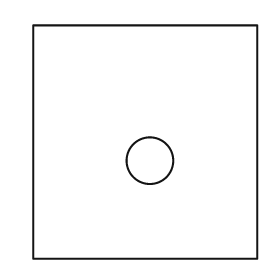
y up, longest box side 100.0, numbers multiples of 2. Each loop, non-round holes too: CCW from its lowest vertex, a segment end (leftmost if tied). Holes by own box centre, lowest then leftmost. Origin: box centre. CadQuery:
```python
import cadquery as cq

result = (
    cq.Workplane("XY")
    .moveTo(-48.0, -50.0)
    .lineTo(48.0, -50.0)
    .lineTo(48.0, 50.0)
    .lineTo(-48.0, 50.0)
    .close()
    .moveTo(2.0, -8.0)
    .circle(10.0)
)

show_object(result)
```